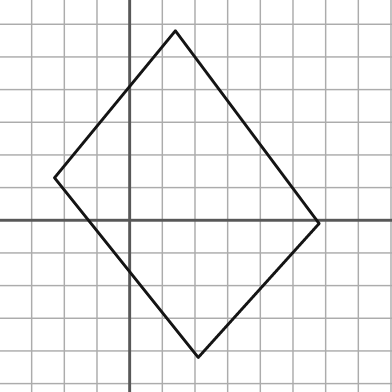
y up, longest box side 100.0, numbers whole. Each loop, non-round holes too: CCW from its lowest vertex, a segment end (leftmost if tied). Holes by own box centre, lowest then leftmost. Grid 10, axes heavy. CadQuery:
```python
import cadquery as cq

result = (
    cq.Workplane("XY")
    .moveTo(21.0, -42.0)
    .lineTo(58.0, -1.0)
    .lineTo(14.0, 58.0)
    .lineTo(-23.0, 13.0)
    .close()
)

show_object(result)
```